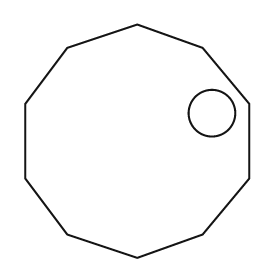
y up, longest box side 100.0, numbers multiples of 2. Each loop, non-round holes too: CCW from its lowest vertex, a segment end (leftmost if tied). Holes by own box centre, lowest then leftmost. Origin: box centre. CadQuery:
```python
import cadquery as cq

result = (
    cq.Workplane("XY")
    .moveTo(0.0, -50.0)
    .lineTo(28.0, -40.0)
    .lineTo(48.0, -16.0)
    .lineTo(48.0, 16.0)
    .lineTo(28.0, 40.0)
    .lineTo(0.0, 50.0)
    .lineTo(-30.0, 40.0)
    .lineTo(-48.0, 16.0)
    .lineTo(-48.0, -16.0)
    .lineTo(-30.0, -40.0)
    .close()
    .moveTo(32.0, 12.0)
    .circle(10.0)
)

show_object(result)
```